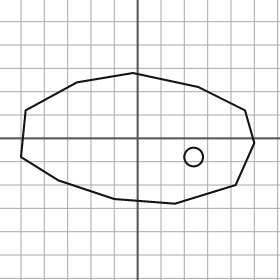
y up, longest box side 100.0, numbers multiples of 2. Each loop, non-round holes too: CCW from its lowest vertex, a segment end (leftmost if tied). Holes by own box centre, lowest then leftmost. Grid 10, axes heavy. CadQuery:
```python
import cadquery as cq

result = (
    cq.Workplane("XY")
    .moveTo(16.0, -28.0)
    .lineTo(42.0, -20.0)
    .lineTo(50.0, -2.0)
    .lineTo(46.0, 12.0)
    .lineTo(26.0, 22.0)
    .lineTo(-2.0, 28.0)
    .lineTo(-26.0, 24.0)
    .lineTo(-48.0, 12.0)
    .lineTo(-50.0, -8.0)
    .lineTo(-34.0, -18.0)
    .lineTo(-10.0, -26.0)
    .close()
    .moveTo(24.0, -8.0)
    .circle(4.0)
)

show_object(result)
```